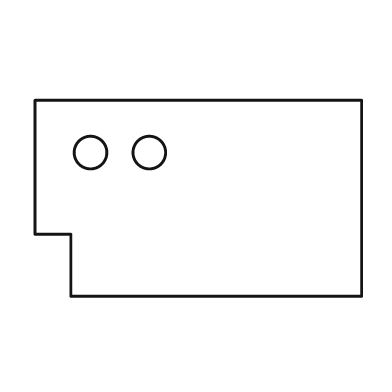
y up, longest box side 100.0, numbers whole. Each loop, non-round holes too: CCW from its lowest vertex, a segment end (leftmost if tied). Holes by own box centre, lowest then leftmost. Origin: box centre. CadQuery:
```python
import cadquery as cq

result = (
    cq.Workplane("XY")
    .moveTo(-39.0, -30.0)
    .lineTo(50.0, -30.0)
    .lineTo(50.0, 30.0)
    .lineTo(-50.0, 30.0)
    .lineTo(-50.0, -11.0)
    .lineTo(-39.0, -11.0)
    .close()
    .moveTo(-33.0, 14.0)
    .circle(5.0)
    .moveTo(-15.0, 14.0)
    .circle(5.0)
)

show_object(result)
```